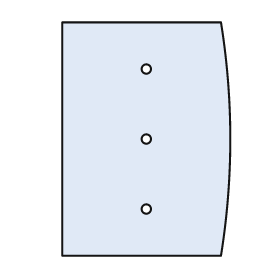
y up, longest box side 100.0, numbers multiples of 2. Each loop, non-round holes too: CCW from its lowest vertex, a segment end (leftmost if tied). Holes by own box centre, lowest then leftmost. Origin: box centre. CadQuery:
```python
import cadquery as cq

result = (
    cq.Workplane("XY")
    .moveTo(-36.0, -50.0)
    .lineTo(32.0, -50.0)
    .threePointArc((36.0, 0.0), (32.0, 50.0))
    .lineTo(-36.0, 50.0)
    .close()
    .moveTo(0.0, -30.0)
    .circle(2.0)
    .moveTo(0.0, 0.0)
    .circle(2.0)
    .moveTo(0.0, 30.0)
    .circle(2.0)
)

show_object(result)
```